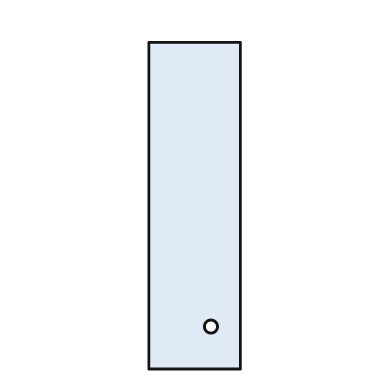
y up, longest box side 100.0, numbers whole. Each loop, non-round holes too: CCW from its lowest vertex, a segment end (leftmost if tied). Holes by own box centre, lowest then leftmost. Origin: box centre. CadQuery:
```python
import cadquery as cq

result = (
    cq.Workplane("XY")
    .moveTo(-14.0, -50.0)
    .lineTo(14.0, -50.0)
    .lineTo(14.0, 50.0)
    .lineTo(-14.0, 50.0)
    .close()
    .moveTo(5.0, -37.0)
    .circle(2.0)
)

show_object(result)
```